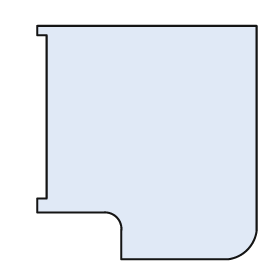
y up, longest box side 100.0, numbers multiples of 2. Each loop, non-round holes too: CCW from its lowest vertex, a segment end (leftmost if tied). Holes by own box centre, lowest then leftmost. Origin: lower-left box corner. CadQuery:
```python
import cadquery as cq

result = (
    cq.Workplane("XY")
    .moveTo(36.0, 0.0)
    .lineTo(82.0, 0.0)
    .threePointArc((90.0, 4.0), (94.0, 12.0))
    .lineTo(94.0, 100.0)
    .lineTo(0.0, 100.0)
    .lineTo(0.0, 96.0)
    .lineTo(4.0, 96.0)
    .lineTo(4.0, 26.0)
    .lineTo(0.0, 26.0)
    .lineTo(0.0, 20.0)
    .lineTo(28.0, 20.0)
    .threePointArc((34.0, 18.0), (36.0, 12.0))
    .close()
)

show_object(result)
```